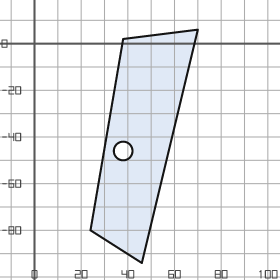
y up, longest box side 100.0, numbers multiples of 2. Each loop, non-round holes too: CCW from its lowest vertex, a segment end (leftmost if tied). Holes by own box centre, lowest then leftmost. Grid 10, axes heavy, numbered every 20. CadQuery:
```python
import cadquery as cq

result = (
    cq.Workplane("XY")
    .moveTo(46.0, -94.0)
    .lineTo(70.0, 6.0)
    .lineTo(38.0, 2.0)
    .lineTo(24.0, -80.0)
    .close()
    .moveTo(38.0, -46.0)
    .circle(4.0)
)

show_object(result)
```